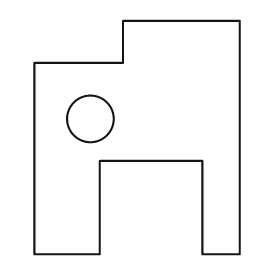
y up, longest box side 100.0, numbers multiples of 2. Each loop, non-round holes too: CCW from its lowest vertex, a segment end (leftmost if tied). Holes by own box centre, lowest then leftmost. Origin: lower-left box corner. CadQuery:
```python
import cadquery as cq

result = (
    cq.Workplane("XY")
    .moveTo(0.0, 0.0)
    .lineTo(28.0, 0.0)
    .lineTo(28.0, 40.0)
    .lineTo(72.0, 40.0)
    .lineTo(72.0, 0.0)
    .lineTo(88.0, 0.0)
    .lineTo(88.0, 100.0)
    .lineTo(38.0, 100.0)
    .lineTo(38.0, 82.0)
    .lineTo(0.0, 82.0)
    .close()
    .moveTo(24.0, 58.0)
    .circle(10.0)
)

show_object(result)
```